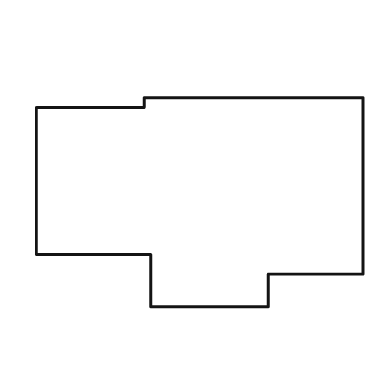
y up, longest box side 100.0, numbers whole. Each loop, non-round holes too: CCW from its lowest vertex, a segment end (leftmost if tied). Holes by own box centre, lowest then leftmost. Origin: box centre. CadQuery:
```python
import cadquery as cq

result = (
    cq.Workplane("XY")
    .moveTo(-15.0, -32.0)
    .lineTo(21.0, -32.0)
    .lineTo(21.0, -22.0)
    .lineTo(50.0, -22.0)
    .lineTo(50.0, 32.0)
    .lineTo(-17.0, 32.0)
    .lineTo(-17.0, 29.0)
    .lineTo(-50.0, 29.0)
    .lineTo(-50.0, -16.0)
    .lineTo(-15.0, -16.0)
    .close()
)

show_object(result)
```